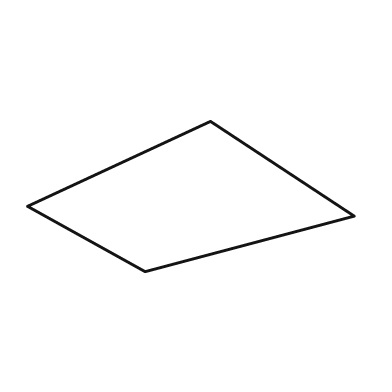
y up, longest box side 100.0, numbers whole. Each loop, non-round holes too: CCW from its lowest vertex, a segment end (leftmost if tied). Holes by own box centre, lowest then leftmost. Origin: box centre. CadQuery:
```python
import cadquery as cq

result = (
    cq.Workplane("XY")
    .moveTo(-14.0, -23.0)
    .lineTo(50.0, -6.0)
    .lineTo(6.0, 23.0)
    .lineTo(-50.0, -3.0)
    .close()
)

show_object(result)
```